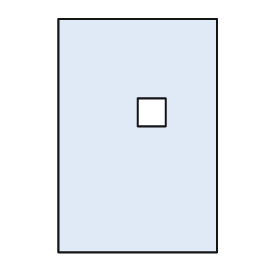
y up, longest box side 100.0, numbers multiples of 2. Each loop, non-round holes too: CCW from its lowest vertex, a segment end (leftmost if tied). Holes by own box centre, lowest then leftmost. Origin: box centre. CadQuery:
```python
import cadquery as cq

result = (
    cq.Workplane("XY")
    .moveTo(-34.0, -50.0)
    .lineTo(34.0, -50.0)
    .lineTo(34.0, 50.0)
    .lineTo(-34.0, 50.0)
    .close()
    .moveTo(0.0, 4.0)
    .lineTo(12.0, 4.0)
    .lineTo(12.0, 16.0)
    .lineTo(0.0, 16.0)
    .close()
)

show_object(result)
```